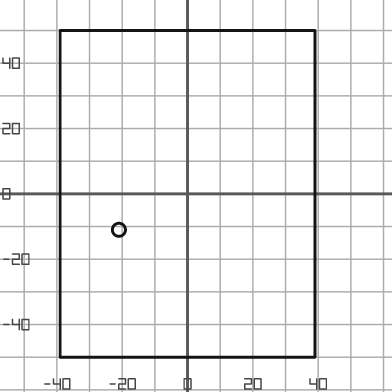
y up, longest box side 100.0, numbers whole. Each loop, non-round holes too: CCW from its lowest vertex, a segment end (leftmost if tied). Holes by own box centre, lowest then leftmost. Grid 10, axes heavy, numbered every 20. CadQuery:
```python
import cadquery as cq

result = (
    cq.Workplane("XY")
    .moveTo(-39.0, -50.0)
    .lineTo(39.0, -50.0)
    .lineTo(39.0, 50.0)
    .lineTo(-39.0, 50.0)
    .close()
    .moveTo(-21.0, -11.0)
    .circle(2.0)
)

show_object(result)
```